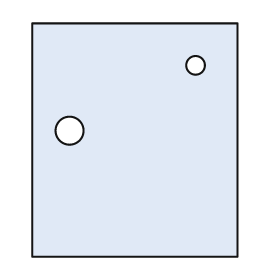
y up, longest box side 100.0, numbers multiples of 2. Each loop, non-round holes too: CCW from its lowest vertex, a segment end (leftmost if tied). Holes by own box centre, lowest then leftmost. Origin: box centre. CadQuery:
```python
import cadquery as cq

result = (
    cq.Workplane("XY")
    .moveTo(-44.0, -50.0)
    .lineTo(44.0, -50.0)
    .lineTo(44.0, 50.0)
    .lineTo(-44.0, 50.0)
    .close()
    .moveTo(-28.0, 4.0)
    .circle(6.0)
    .moveTo(26.0, 32.0)
    .circle(4.0)
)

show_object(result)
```